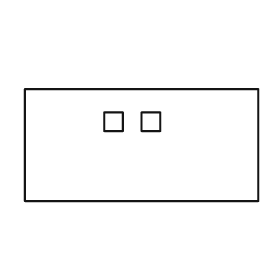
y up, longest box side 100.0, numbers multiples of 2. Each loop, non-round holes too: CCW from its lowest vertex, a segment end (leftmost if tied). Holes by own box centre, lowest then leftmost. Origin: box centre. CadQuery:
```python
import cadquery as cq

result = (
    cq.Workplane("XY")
    .moveTo(-50.0, -24.0)
    .lineTo(50.0, -24.0)
    .lineTo(50.0, 24.0)
    .lineTo(-50.0, 24.0)
    .close()
    .moveTo(-16.0, 6.0)
    .lineTo(-8.0, 6.0)
    .lineTo(-8.0, 14.0)
    .lineTo(-16.0, 14.0)
    .close()
    .moveTo(0.0, 6.0)
    .lineTo(8.0, 6.0)
    .lineTo(8.0, 14.0)
    .lineTo(0.0, 14.0)
    .close()
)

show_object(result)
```